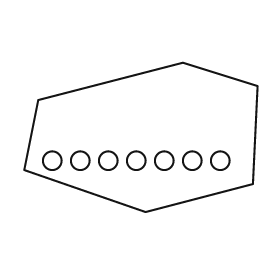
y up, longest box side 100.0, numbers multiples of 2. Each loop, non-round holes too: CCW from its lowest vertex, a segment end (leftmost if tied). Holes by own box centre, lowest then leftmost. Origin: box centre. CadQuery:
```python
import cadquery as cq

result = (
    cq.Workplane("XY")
    .moveTo(2.0, -32.0)
    .lineTo(48.0, -20.0)
    .lineTo(50.0, 22.0)
    .lineTo(18.0, 32.0)
    .lineTo(-44.0, 16.0)
    .lineTo(-50.0, -14.0)
    .close()
    .moveTo(-38.0, -10.0)
    .circle(4.0)
    .moveTo(-26.0, -10.0)
    .circle(4.0)
    .moveTo(-14.0, -10.0)
    .circle(4.0)
    .moveTo(-2.0, -10.0)
    .circle(4.0)
    .moveTo(10.0, -10.0)
    .circle(4.0)
    .moveTo(22.0, -10.0)
    .circle(4.0)
    .moveTo(34.0, -10.0)
    .circle(4.0)
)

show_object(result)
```